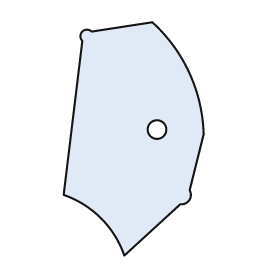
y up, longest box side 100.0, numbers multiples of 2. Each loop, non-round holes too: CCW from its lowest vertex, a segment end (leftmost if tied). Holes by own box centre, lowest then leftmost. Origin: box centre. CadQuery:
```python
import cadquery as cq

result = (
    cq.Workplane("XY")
    .moveTo(-4.0, -50.0)
    .lineTo(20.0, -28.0)
    .threePointArc((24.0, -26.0), (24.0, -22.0))
    .lineTo(30.0, 2.0)
    .threePointArc((24.0, 28.0), (8.0, 50.0))
    .lineTo(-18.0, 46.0)
    .threePointArc((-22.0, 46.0), (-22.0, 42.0))
    .lineTo(-30.0, -24.0)
    .threePointArc((-14.0, -34.0), (-4.0, -50.0))
    .close()
    .moveTo(10.0, 4.0)
    .circle(4.0)
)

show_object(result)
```